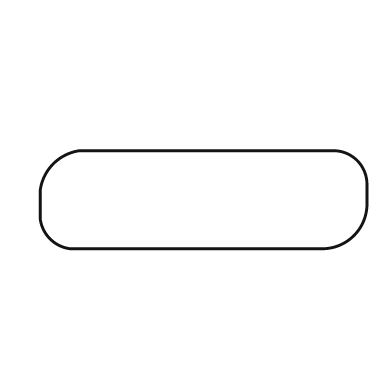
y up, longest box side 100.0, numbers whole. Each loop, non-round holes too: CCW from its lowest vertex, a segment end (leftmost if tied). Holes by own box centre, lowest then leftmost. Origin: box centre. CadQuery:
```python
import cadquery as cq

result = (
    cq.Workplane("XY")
    .moveTo(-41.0, -15.0)
    .lineTo(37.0, -15.0)
    .threePointArc((46.0, -11.0), (50.0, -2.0))
    .lineTo(50.0, 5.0)
    .threePointArc((47.0, 12.0), (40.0, 15.0))
    .lineTo(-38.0, 15.0)
    .threePointArc((-46.0, 11.0), (-50.0, 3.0))
    .lineTo(-50.0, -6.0)
    .threePointArc((-47.0, -12.0), (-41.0, -15.0))
    .close()
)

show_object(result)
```